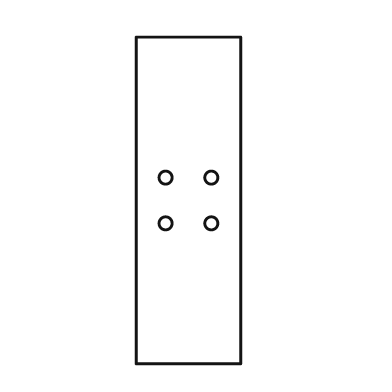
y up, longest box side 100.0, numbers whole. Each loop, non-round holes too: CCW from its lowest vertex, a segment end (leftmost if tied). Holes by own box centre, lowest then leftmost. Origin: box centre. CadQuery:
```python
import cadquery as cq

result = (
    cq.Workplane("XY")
    .moveTo(-16.0, -50.0)
    .lineTo(16.0, -50.0)
    .lineTo(16.0, 50.0)
    .lineTo(-16.0, 50.0)
    .close()
    .moveTo(-7.0, -7.0)
    .circle(2.0)
    .moveTo(7.0, -7.0)
    .circle(2.0)
    .moveTo(-7.0, 7.0)
    .circle(2.0)
    .moveTo(7.0, 7.0)
    .circle(2.0)
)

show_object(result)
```